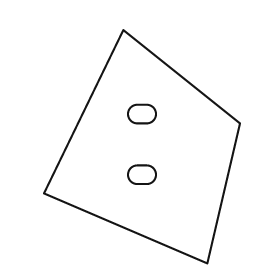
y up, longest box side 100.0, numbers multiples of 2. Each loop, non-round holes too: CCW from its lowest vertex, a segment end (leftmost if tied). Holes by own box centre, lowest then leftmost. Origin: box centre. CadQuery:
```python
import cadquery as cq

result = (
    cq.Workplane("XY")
    .moveTo(28.0, -50.0)
    .lineTo(42.0, 10.0)
    .lineTo(-8.0, 50.0)
    .lineTo(-42.0, -20.0)
    .close()
    .moveTo(-2.0, -16.0)
    .lineTo(2.0, -16.0)
    .threePointArc((6.0, -12.0), (2.0, -8.0))
    .lineTo(-2.0, -8.0)
    .threePointArc((-6.0, -12.0), (-2.0, -16.0))
    .close()
    .moveTo(-2.0, 10.0)
    .lineTo(2.0, 10.0)
    .threePointArc((6.0, 14.0), (2.0, 18.0))
    .lineTo(-2.0, 18.0)
    .threePointArc((-6.0, 14.0), (-2.0, 10.0))
    .close()
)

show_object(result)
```